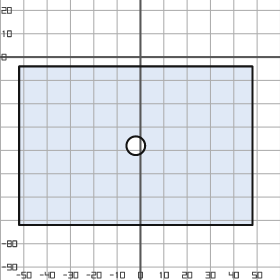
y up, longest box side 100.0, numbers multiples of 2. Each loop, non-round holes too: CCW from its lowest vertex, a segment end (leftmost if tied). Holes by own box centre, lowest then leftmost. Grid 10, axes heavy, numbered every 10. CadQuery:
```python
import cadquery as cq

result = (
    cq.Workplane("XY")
    .moveTo(-52.0, -72.0)
    .lineTo(48.0, -72.0)
    .lineTo(48.0, -4.0)
    .lineTo(-52.0, -4.0)
    .close()
    .moveTo(-2.0, -38.0)
    .circle(4.0)
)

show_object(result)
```